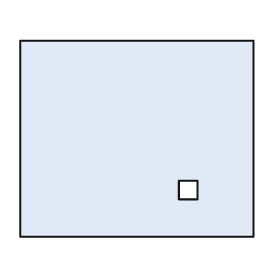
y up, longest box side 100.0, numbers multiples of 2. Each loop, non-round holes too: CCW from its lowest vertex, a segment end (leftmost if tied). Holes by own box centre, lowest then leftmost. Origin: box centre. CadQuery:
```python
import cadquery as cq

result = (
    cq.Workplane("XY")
    .moveTo(-50.0, -42.0)
    .lineTo(50.0, -42.0)
    .lineTo(50.0, 42.0)
    .lineTo(-50.0, 42.0)
    .close()
    .moveTo(18.0, -26.0)
    .lineTo(26.0, -26.0)
    .lineTo(26.0, -18.0)
    .lineTo(18.0, -18.0)
    .close()
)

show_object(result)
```